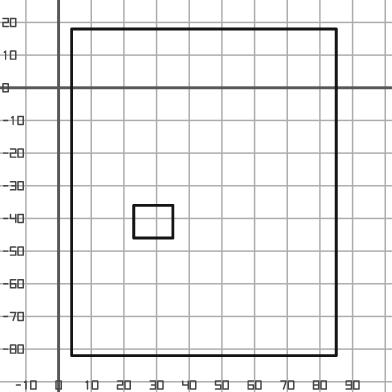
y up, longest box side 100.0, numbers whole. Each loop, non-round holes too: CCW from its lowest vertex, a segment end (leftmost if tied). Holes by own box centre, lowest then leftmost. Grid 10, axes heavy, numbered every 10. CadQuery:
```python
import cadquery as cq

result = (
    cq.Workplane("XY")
    .moveTo(4.0, -82.0)
    .lineTo(85.0, -82.0)
    .lineTo(85.0, 18.0)
    .lineTo(4.0, 18.0)
    .close()
    .moveTo(23.0, -46.0)
    .lineTo(35.0, -46.0)
    .lineTo(35.0, -36.0)
    .lineTo(23.0, -36.0)
    .close()
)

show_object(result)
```